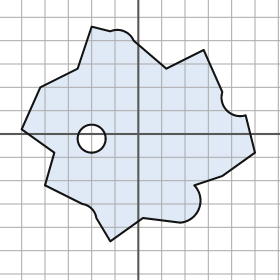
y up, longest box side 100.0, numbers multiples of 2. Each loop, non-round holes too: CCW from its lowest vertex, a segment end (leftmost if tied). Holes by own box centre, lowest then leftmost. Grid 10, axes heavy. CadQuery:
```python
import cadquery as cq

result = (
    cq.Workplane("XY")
    .moveTo(-12.0, -46.0)
    .lineTo(2.0, -36.0)
    .lineTo(18.0, -38.0)
    .threePointArc((26.0, -32.0), (24.0, -22.0))
    .lineTo(36.0, -18.0)
    .lineTo(50.0, -8.0)
    .lineTo(46.0, 8.0)
    .threePointArc((38.0, 10.0), (36.0, 18.0))
    .lineTo(28.0, 36.0)
    .lineTo(12.0, 28.0)
    .lineTo(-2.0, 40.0)
    .threePointArc((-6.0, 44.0), (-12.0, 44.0))
    .lineTo(-20.0, 46.0)
    .lineTo(-26.0, 28.0)
    .lineTo(-42.0, 20.0)
    .lineTo(-50.0, 2.0)
    .lineTo(-36.0, -8.0)
    .lineTo(-40.0, -22.0)
    .lineTo(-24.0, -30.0)
    .threePointArc((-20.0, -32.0), (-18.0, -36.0))
    .close()
    .moveTo(-20.0, -2.0)
    .circle(6.0)
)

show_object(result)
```